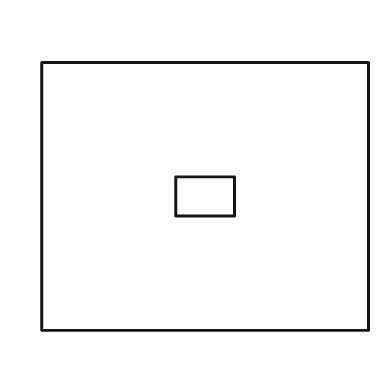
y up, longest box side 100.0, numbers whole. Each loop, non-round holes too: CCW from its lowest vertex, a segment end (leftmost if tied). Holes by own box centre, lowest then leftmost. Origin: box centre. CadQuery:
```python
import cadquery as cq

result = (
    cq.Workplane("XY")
    .moveTo(-50.0, -41.0)
    .lineTo(50.0, -41.0)
    .lineTo(50.0, 41.0)
    .lineTo(-50.0, 41.0)
    .close()
    .moveTo(-9.0, -6.0)
    .lineTo(9.0, -6.0)
    .lineTo(9.0, 6.0)
    .lineTo(-9.0, 6.0)
    .close()
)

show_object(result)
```